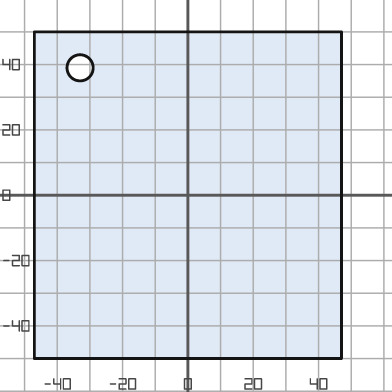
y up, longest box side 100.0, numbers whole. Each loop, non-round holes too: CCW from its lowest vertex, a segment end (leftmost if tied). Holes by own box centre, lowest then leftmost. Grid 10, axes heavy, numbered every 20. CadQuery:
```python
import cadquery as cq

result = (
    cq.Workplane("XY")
    .moveTo(-47.0, -50.0)
    .lineTo(47.0, -50.0)
    .lineTo(47.0, 50.0)
    .lineTo(-47.0, 50.0)
    .close()
    .moveTo(-33.0, 39.0)
    .circle(4.0)
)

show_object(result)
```